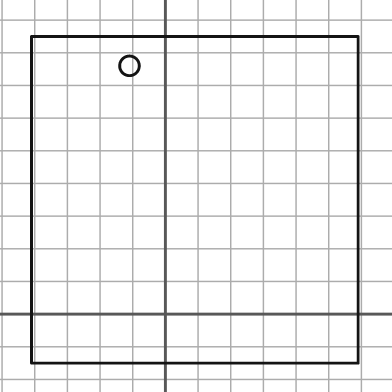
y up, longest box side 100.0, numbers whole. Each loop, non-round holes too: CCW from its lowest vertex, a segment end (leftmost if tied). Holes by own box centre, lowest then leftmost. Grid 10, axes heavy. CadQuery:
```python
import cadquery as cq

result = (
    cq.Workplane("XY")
    .moveTo(-41.0, -15.0)
    .lineTo(59.0, -15.0)
    .lineTo(59.0, 85.0)
    .lineTo(-41.0, 85.0)
    .close()
    .moveTo(-11.0, 76.0)
    .circle(3.0)
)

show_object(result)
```